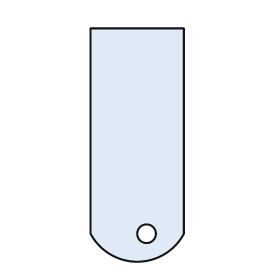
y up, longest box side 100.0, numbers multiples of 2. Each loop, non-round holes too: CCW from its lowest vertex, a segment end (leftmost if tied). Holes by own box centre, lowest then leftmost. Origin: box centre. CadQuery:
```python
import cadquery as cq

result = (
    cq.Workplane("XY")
    .moveTo(-20.0, -38.0)
    .threePointArc((0.0, -50.0), (20.0, -38.0))
    .lineTo(20.0, 50.0)
    .lineTo(-20.0, 50.0)
    .close()
    .moveTo(4.0, -38.0)
    .circle(4.0)
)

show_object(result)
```